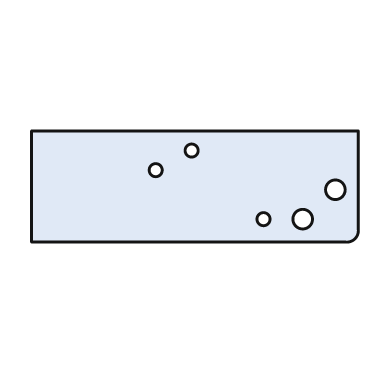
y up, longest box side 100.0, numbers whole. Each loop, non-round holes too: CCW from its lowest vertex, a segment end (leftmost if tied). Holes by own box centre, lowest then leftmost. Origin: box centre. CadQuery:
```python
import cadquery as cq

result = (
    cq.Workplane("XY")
    .moveTo(-50.0, -17.0)
    .lineTo(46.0, -17.0)
    .threePointArc((49.0, -16.0), (50.0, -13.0))
    .lineTo(50.0, 17.0)
    .lineTo(-50.0, 17.0)
    .close()
    .moveTo(21.0, -10.0)
    .circle(2.0)
    .moveTo(33.0, -10.0)
    .circle(3.0)
    .moveTo(43.0, -1.0)
    .circle(3.0)
    .moveTo(-12.0, 5.0)
    .circle(2.0)
    .moveTo(-1.0, 11.0)
    .circle(2.0)
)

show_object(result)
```